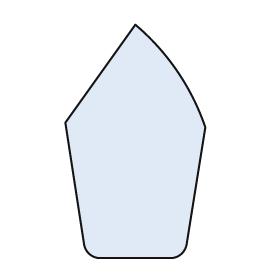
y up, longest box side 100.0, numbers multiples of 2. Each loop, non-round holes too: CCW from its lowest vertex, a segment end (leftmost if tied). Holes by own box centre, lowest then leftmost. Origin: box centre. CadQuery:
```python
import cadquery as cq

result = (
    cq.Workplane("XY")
    .moveTo(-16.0, -50.0)
    .lineTo(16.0, -50.0)
    .threePointArc((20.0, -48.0), (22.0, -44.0))
    .lineTo(30.0, 6.0)
    .threePointArc((18.0, 30.0), (0.0, 50.0))
    .lineTo(-30.0, 8.0)
    .lineTo(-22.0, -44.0)
    .threePointArc((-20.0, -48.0), (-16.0, -50.0))
    .close()
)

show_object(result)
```